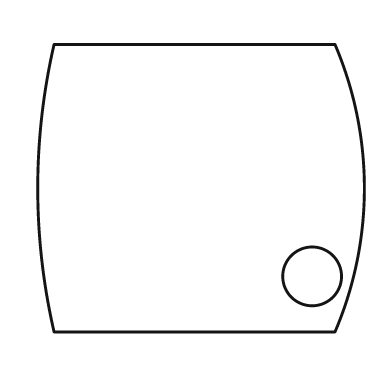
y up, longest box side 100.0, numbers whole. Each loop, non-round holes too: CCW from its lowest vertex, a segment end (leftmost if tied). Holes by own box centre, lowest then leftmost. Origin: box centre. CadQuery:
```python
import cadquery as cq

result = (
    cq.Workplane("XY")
    .moveTo(-45.0, -44.0)
    .lineTo(41.0, -44.0)
    .threePointArc((50.0, 0.0), (41.0, 44.0))
    .lineTo(-45.0, 44.0)
    .threePointArc((-50.0, 0.0), (-45.0, -44.0))
    .close()
    .moveTo(34.0, -27.0)
    .circle(9.0)
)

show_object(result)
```